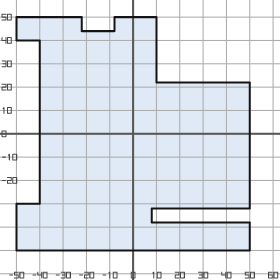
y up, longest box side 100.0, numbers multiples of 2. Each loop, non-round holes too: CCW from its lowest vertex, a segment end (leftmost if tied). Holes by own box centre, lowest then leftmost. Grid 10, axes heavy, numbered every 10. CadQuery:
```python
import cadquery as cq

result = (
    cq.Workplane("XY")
    .moveTo(-50.0, -50.0)
    .lineTo(50.0, -50.0)
    .lineTo(50.0, -38.0)
    .lineTo(8.0, -38.0)
    .lineTo(8.0, -32.0)
    .lineTo(50.0, -32.0)
    .lineTo(50.0, 22.0)
    .lineTo(10.0, 22.0)
    .lineTo(10.0, 50.0)
    .lineTo(-8.0, 50.0)
    .lineTo(-8.0, 44.0)
    .lineTo(-22.0, 44.0)
    .lineTo(-22.0, 50.0)
    .lineTo(-50.0, 50.0)
    .lineTo(-50.0, 40.0)
    .lineTo(-40.0, 40.0)
    .lineTo(-40.0, -30.0)
    .lineTo(-50.0, -30.0)
    .close()
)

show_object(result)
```